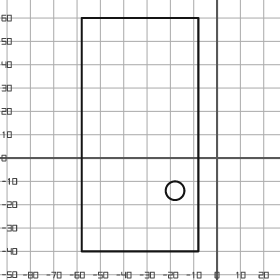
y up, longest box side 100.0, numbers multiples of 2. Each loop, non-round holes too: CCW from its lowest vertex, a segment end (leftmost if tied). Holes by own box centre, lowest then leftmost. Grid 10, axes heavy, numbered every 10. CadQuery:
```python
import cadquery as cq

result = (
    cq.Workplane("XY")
    .moveTo(-58.0, -40.0)
    .lineTo(-8.0, -40.0)
    .lineTo(-8.0, 60.0)
    .lineTo(-58.0, 60.0)
    .close()
    .moveTo(-18.0, -14.0)
    .circle(4.0)
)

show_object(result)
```